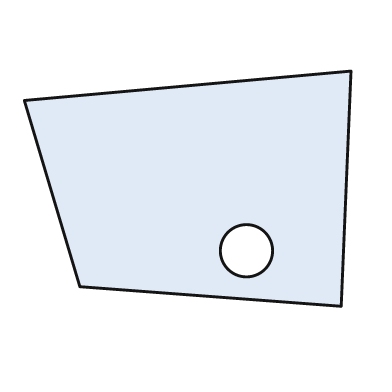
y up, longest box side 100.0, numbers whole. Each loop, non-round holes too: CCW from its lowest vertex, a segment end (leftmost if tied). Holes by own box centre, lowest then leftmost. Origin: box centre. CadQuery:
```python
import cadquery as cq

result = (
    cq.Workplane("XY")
    .moveTo(47.0, -36.0)
    .lineTo(50.0, 36.0)
    .lineTo(-50.0, 27.0)
    .lineTo(-33.0, -30.0)
    .close()
    .moveTo(18.0, -19.0)
    .circle(8.0)
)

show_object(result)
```